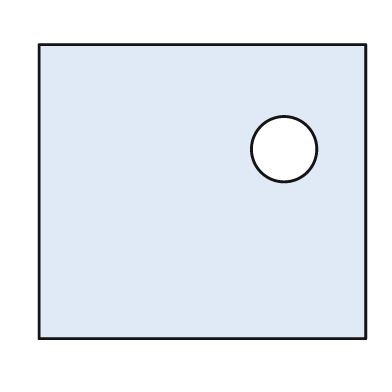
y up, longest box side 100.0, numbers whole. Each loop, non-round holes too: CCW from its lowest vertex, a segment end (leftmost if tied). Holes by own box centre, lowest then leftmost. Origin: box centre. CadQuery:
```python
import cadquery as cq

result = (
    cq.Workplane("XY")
    .moveTo(-50.0, -45.0)
    .lineTo(50.0, -45.0)
    .lineTo(50.0, 45.0)
    .lineTo(-50.0, 45.0)
    .close()
    .moveTo(25.0, 13.0)
    .circle(10.0)
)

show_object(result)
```